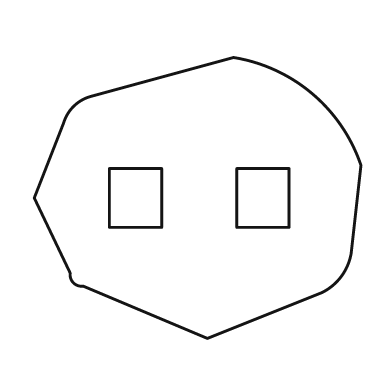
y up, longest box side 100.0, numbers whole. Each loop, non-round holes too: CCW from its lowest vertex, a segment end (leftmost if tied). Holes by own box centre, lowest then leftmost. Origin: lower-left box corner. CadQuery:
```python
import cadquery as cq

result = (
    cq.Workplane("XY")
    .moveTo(53.0, 0.0)
    .lineTo(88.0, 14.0)
    .threePointArc((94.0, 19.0), (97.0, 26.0))
    .lineTo(100.0, 53.0)
    .threePointArc((85.0, 75.0), (61.0, 86.0))
    .lineTo(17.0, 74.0)
    .threePointArc((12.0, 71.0), (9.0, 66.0))
    .lineTo(0.0, 43.0)
    .lineTo(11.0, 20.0)
    .threePointArc((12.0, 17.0), (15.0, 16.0))
    .close()
    .moveTo(23.0, 34.0)
    .lineTo(39.0, 34.0)
    .lineTo(39.0, 52.0)
    .lineTo(23.0, 52.0)
    .close()
    .moveTo(62.0, 34.0)
    .lineTo(78.0, 34.0)
    .lineTo(78.0, 52.0)
    .lineTo(62.0, 52.0)
    .close()
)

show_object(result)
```